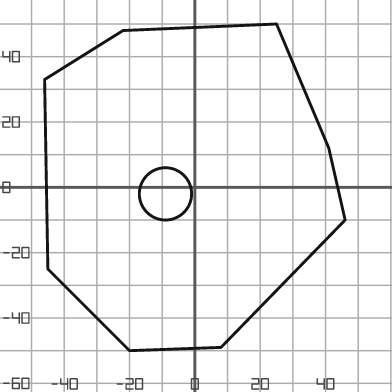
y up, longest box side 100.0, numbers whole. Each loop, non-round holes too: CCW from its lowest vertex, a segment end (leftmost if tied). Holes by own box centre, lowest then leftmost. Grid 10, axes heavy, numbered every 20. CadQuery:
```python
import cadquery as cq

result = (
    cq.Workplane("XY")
    .moveTo(-20.0, -50.0)
    .lineTo(8.0, -49.0)
    .lineTo(46.0, -10.0)
    .lineTo(41.0, 12.0)
    .lineTo(25.0, 50.0)
    .lineTo(-22.0, 48.0)
    .lineTo(-46.0, 33.0)
    .lineTo(-45.0, -25.0)
    .close()
    .moveTo(-9.0, -2.0)
    .circle(8.0)
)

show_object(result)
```